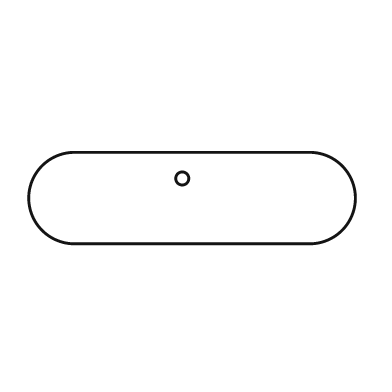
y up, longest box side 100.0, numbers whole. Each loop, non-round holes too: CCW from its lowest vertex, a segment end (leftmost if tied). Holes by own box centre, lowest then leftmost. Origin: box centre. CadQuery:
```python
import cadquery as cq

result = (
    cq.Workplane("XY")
    .moveTo(-36.0, -14.0)
    .lineTo(36.0, -14.0)
    .threePointArc((50.0, 0.0), (36.0, 14.0))
    .lineTo(-36.0, 14.0)
    .threePointArc((-50.0, 0.0), (-36.0, -14.0))
    .close()
    .moveTo(-3.0, 6.0)
    .circle(2.0)
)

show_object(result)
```